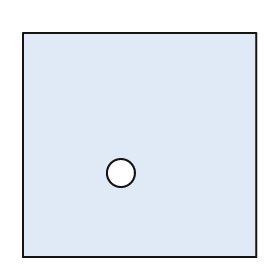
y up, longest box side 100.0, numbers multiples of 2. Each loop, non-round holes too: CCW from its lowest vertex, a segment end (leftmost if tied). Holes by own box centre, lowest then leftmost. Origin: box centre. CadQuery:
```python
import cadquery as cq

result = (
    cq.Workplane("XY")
    .moveTo(-50.0, -48.0)
    .lineTo(50.0, -48.0)
    .lineTo(50.0, 48.0)
    .lineTo(-50.0, 48.0)
    .close()
    .moveTo(-8.0, -12.0)
    .circle(6.0)
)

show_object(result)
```